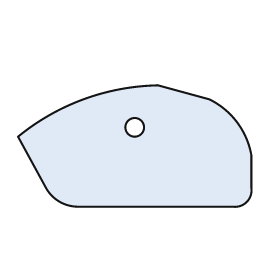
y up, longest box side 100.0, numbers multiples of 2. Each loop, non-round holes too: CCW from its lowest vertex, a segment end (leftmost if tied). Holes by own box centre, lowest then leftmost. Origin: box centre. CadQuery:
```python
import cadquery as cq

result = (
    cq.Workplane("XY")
    .moveTo(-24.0, -26.0)
    .lineTo(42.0, -26.0)
    .threePointArc((48.0, -24.0), (50.0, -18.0))
    .lineTo(50.0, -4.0)
    .threePointArc((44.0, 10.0), (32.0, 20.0))
    .lineTo(10.0, 26.0)
    .threePointArc((-22.0, 20.0), (-50.0, 4.0))
    .lineTo(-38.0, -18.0)
    .threePointArc((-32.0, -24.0), (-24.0, -26.0))
    .close()
    .moveTo(0.0, 8.0)
    .circle(4.0)
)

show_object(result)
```